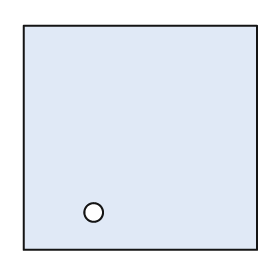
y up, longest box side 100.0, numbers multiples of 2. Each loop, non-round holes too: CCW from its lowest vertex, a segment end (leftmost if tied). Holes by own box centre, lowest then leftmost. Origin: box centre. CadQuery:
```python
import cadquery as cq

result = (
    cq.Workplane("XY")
    .moveTo(-50.0, -48.0)
    .lineTo(50.0, -48.0)
    .lineTo(50.0, 48.0)
    .lineTo(-50.0, 48.0)
    .close()
    .moveTo(-20.0, -32.0)
    .circle(4.0)
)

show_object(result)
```